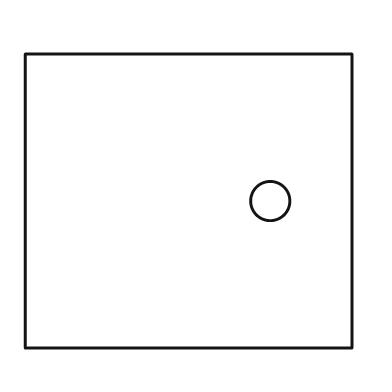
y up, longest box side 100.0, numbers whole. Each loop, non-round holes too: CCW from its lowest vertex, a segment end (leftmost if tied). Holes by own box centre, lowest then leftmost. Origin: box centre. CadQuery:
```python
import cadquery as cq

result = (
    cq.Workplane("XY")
    .moveTo(-50.0, -45.0)
    .lineTo(50.0, -45.0)
    .lineTo(50.0, 45.0)
    .lineTo(-50.0, 45.0)
    .close()
    .moveTo(25.0, 0.0)
    .circle(6.0)
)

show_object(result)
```